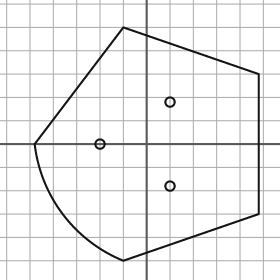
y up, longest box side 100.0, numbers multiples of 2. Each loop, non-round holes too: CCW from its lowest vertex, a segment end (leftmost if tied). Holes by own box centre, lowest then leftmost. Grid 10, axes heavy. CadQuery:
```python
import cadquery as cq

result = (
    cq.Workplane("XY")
    .moveTo(-10.0, -50.0)
    .lineTo(48.0, -30.0)
    .lineTo(48.0, 30.0)
    .lineTo(-10.0, 50.0)
    .lineTo(-48.0, 0.0)
    .threePointArc((-36.0, -30.0), (-10.0, -50.0))
    .close()
    .moveTo(10.0, -18.0)
    .circle(2.0)
    .moveTo(-20.0, 0.0)
    .circle(2.0)
    .moveTo(10.0, 18.0)
    .circle(2.0)
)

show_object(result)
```